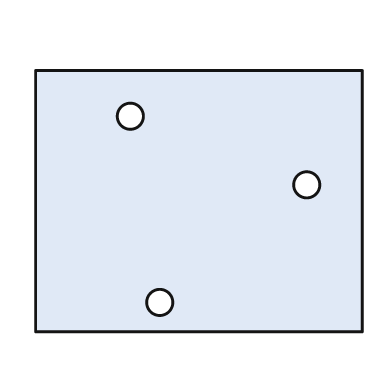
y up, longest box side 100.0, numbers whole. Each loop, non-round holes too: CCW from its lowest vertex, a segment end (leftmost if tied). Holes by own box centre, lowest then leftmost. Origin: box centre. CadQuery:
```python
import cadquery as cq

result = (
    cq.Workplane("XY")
    .moveTo(-50.0, -40.0)
    .lineTo(50.0, -40.0)
    .lineTo(50.0, 40.0)
    .lineTo(-50.0, 40.0)
    .close()
    .moveTo(-12.0, -31.0)
    .circle(4.0)
    .moveTo(33.0, 5.0)
    .circle(4.0)
    .moveTo(-21.0, 26.0)
    .circle(4.0)
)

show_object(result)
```